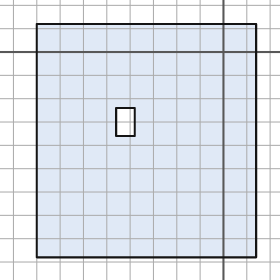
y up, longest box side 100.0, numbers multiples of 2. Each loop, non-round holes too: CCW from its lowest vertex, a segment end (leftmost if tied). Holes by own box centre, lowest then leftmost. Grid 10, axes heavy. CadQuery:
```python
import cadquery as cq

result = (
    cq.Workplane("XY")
    .moveTo(-80.0, -88.0)
    .lineTo(14.0, -88.0)
    .lineTo(14.0, 12.0)
    .lineTo(-80.0, 12.0)
    .close()
    .moveTo(-46.0, -36.0)
    .lineTo(-38.0, -36.0)
    .lineTo(-38.0, -24.0)
    .lineTo(-46.0, -24.0)
    .close()
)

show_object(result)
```